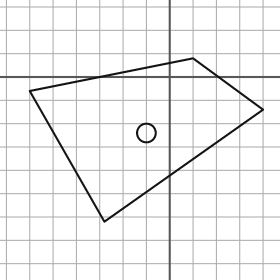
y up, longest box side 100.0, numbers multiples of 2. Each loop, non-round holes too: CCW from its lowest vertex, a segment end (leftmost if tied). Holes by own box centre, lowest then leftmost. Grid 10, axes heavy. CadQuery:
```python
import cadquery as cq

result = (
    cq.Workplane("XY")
    .moveTo(-28.0, -62.0)
    .lineTo(40.0, -14.0)
    .lineTo(10.0, 8.0)
    .lineTo(-60.0, -6.0)
    .close()
    .moveTo(-10.0, -24.0)
    .circle(4.0)
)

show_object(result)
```